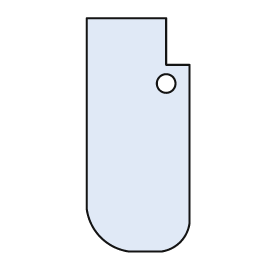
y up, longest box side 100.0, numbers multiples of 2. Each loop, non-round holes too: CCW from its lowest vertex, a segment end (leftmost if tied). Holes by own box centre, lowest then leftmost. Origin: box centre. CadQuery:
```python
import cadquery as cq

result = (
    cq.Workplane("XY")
    .moveTo(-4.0, -50.0)
    .lineTo(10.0, -50.0)
    .threePointArc((18.0, -46.0), (22.0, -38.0))
    .lineTo(22.0, 30.0)
    .lineTo(12.0, 30.0)
    .lineTo(12.0, 50.0)
    .lineTo(-22.0, 50.0)
    .lineTo(-22.0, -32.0)
    .threePointArc((-16.0, -44.0), (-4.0, -50.0))
    .close()
    .moveTo(12.0, 22.0)
    .circle(4.0)
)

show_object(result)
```